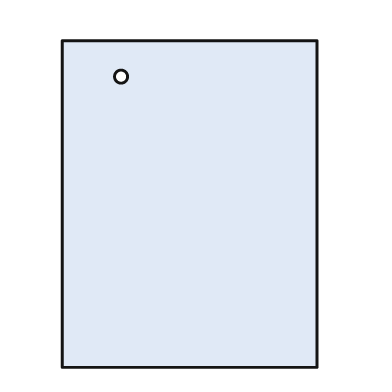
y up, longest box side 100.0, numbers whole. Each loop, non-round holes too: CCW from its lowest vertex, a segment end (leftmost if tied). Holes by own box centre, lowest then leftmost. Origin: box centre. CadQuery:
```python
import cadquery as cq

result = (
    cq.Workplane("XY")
    .moveTo(-39.0, -50.0)
    .lineTo(39.0, -50.0)
    .lineTo(39.0, 50.0)
    .lineTo(-39.0, 50.0)
    .close()
    .moveTo(-21.0, 39.0)
    .circle(2.0)
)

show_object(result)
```